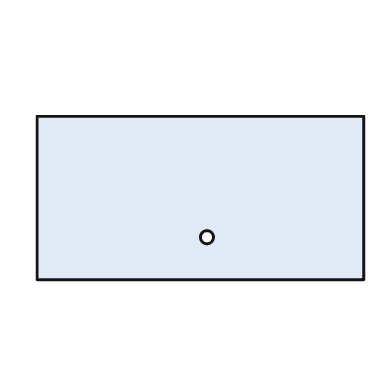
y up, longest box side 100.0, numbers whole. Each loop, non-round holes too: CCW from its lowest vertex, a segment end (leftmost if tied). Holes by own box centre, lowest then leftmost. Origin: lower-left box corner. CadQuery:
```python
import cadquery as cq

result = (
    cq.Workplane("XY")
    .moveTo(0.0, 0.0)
    .lineTo(100.0, 0.0)
    .lineTo(100.0, 50.0)
    .lineTo(0.0, 50.0)
    .close()
    .moveTo(52.0, 13.0)
    .circle(2.0)
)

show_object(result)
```